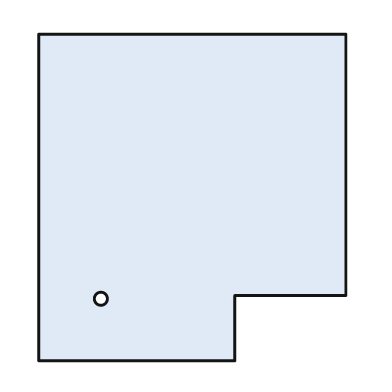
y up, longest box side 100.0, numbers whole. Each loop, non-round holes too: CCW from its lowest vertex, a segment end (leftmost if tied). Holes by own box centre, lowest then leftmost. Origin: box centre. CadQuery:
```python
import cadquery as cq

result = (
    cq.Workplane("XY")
    .moveTo(-47.0, -50.0)
    .lineTo(13.0, -50.0)
    .lineTo(13.0, -30.0)
    .lineTo(47.0, -30.0)
    .lineTo(47.0, 50.0)
    .lineTo(-47.0, 50.0)
    .close()
    .moveTo(-28.0, -31.0)
    .circle(2.0)
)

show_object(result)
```